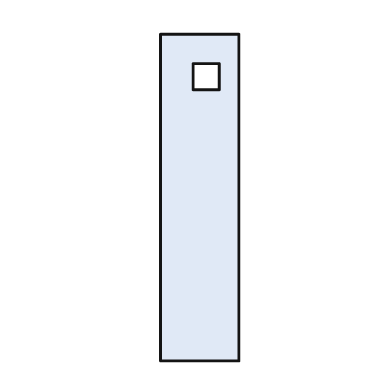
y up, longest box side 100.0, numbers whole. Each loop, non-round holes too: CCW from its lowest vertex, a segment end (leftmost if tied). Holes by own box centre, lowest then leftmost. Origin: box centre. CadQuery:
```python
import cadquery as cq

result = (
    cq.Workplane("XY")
    .moveTo(-12.0, -50.0)
    .lineTo(12.0, -50.0)
    .lineTo(12.0, 50.0)
    .lineTo(-12.0, 50.0)
    .close()
    .moveTo(-2.0, 33.0)
    .lineTo(6.0, 33.0)
    .lineTo(6.0, 41.0)
    .lineTo(-2.0, 41.0)
    .close()
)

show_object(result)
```